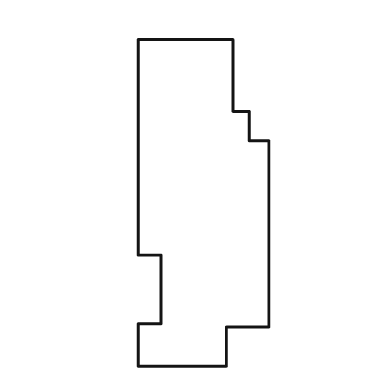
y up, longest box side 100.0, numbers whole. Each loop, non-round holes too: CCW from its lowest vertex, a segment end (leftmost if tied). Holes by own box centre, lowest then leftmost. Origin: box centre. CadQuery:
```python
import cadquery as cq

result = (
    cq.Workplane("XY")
    .moveTo(-20.0, -50.0)
    .lineTo(7.0, -50.0)
    .lineTo(7.0, -38.0)
    .lineTo(20.0, -38.0)
    .lineTo(20.0, 19.0)
    .lineTo(14.0, 19.0)
    .lineTo(14.0, 28.0)
    .lineTo(9.0, 28.0)
    .lineTo(9.0, 50.0)
    .lineTo(-20.0, 50.0)
    .lineTo(-20.0, -16.0)
    .lineTo(-13.0, -16.0)
    .lineTo(-13.0, -37.0)
    .lineTo(-20.0, -37.0)
    .close()
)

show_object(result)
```